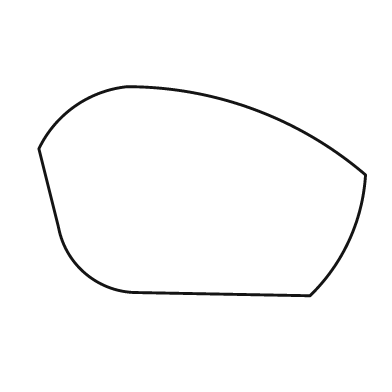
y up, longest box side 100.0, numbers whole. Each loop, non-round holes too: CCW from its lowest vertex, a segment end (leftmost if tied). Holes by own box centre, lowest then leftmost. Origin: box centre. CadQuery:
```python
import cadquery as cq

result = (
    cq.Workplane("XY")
    .moveTo(33.0, -32.0)
    .threePointArc((45.0, -15.0), (50.0, 5.0))
    .threePointArc((16.0, 25.0), (-23.0, 32.0))
    .threePointArc((-39.0, 26.0), (-50.0, 13.0))
    .lineTo(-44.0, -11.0)
    .threePointArc((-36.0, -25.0), (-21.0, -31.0))
    .close()
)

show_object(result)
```